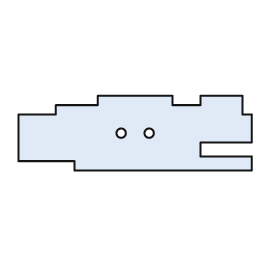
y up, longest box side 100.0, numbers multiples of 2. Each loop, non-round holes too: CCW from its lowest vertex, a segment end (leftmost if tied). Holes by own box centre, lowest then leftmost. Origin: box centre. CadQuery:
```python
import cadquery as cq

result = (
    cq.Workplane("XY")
    .moveTo(-26.0, -16.0)
    .lineTo(50.0, -16.0)
    .lineTo(50.0, -10.0)
    .lineTo(28.0, -10.0)
    .lineTo(28.0, -4.0)
    .lineTo(50.0, -4.0)
    .lineTo(50.0, 8.0)
    .lineTo(46.0, 8.0)
    .lineTo(46.0, 16.0)
    .lineTo(28.0, 16.0)
    .lineTo(28.0, 12.0)
    .lineTo(16.0, 12.0)
    .lineTo(16.0, 16.0)
    .lineTo(-16.0, 16.0)
    .lineTo(-16.0, 12.0)
    .lineTo(-34.0, 12.0)
    .lineTo(-34.0, 8.0)
    .lineTo(-50.0, 8.0)
    .lineTo(-50.0, -12.0)
    .lineTo(-26.0, -12.0)
    .close()
    .moveTo(-6.0, 0.0)
    .circle(2.0)
    .moveTo(6.0, 0.0)
    .circle(2.0)
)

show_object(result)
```